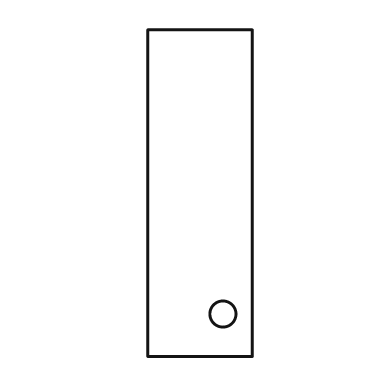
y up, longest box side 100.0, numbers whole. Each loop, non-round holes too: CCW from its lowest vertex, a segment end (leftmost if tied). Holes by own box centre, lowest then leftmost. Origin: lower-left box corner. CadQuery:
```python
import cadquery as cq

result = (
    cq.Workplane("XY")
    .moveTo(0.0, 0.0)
    .lineTo(32.0, 0.0)
    .lineTo(32.0, 100.0)
    .lineTo(0.0, 100.0)
    .close()
    .moveTo(23.0, 13.0)
    .circle(4.0)
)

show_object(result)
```